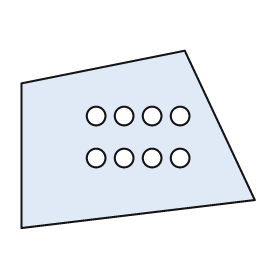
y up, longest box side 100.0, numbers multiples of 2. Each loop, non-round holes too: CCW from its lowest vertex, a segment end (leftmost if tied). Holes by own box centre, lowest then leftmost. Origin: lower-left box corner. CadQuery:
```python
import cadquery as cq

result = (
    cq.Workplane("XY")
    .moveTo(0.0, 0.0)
    .lineTo(100.0, 12.0)
    .lineTo(70.0, 76.0)
    .lineTo(0.0, 62.0)
    .close()
    .moveTo(32.0, 30.0)
    .circle(4.0)
    .moveTo(44.0, 30.0)
    .circle(4.0)
    .moveTo(56.0, 30.0)
    .circle(4.0)
    .moveTo(68.0, 30.0)
    .circle(4.0)
    .moveTo(32.0, 48.0)
    .circle(4.0)
    .moveTo(44.0, 48.0)
    .circle(4.0)
    .moveTo(56.0, 48.0)
    .circle(4.0)
    .moveTo(68.0, 48.0)
    .circle(4.0)
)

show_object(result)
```